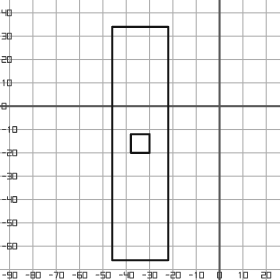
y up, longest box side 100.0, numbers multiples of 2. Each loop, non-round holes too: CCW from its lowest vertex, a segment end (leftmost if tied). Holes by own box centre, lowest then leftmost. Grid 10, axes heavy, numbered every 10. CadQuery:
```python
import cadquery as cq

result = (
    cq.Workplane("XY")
    .moveTo(-46.0, -66.0)
    .lineTo(-22.0, -66.0)
    .lineTo(-22.0, 34.0)
    .lineTo(-46.0, 34.0)
    .close()
    .moveTo(-38.0, -20.0)
    .lineTo(-30.0, -20.0)
    .lineTo(-30.0, -12.0)
    .lineTo(-38.0, -12.0)
    .close()
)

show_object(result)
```